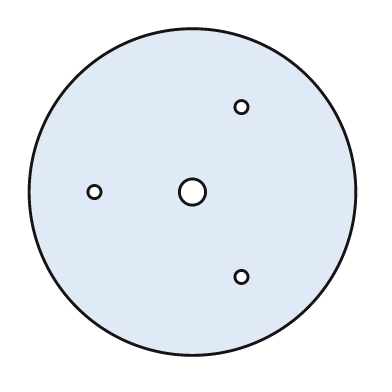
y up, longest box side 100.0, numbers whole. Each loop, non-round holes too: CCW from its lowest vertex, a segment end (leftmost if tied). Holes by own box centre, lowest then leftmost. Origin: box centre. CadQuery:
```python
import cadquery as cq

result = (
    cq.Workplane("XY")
    .moveTo(0.0, 0.0)
    .circle(50.0)
    .moveTo(15.0, -26.0)
    .circle(2.0)
    .moveTo(-30.0, 0.0)
    .circle(2.0)
    .moveTo(0.0, 0.0)
    .circle(4.0)
    .moveTo(15.0, 26.0)
    .circle(2.0)
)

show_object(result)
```